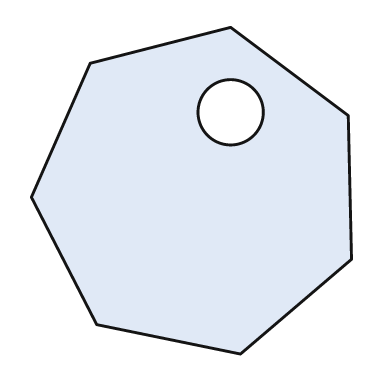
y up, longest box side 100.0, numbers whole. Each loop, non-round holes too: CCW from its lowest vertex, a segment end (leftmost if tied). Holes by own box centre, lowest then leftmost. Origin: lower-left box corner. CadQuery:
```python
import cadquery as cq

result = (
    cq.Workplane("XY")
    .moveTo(64.0, 0.0)
    .lineTo(98.0, 29.0)
    .lineTo(97.0, 73.0)
    .lineTo(61.0, 100.0)
    .lineTo(18.0, 89.0)
    .lineTo(0.0, 48.0)
    .lineTo(20.0, 9.0)
    .close()
    .moveTo(61.0, 74.0)
    .circle(10.0)
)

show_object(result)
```